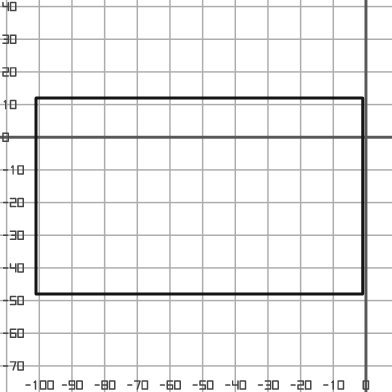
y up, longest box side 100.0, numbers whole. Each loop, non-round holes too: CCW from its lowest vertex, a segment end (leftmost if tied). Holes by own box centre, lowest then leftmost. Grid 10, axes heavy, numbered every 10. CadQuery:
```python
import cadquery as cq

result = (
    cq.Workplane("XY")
    .moveTo(-101.0, -48.0)
    .lineTo(-1.0, -48.0)
    .lineTo(-1.0, 12.0)
    .lineTo(-101.0, 12.0)
    .close()
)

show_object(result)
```